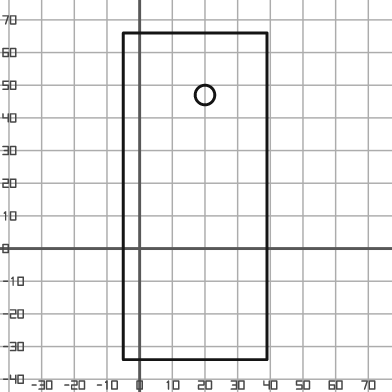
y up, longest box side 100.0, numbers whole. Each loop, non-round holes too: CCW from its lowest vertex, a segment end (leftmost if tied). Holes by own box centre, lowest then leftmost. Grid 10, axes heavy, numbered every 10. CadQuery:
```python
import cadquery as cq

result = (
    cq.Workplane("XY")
    .moveTo(-5.0, -34.0)
    .lineTo(39.0, -34.0)
    .lineTo(39.0, 66.0)
    .lineTo(-5.0, 66.0)
    .close()
    .moveTo(20.0, 47.0)
    .circle(3.0)
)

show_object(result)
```